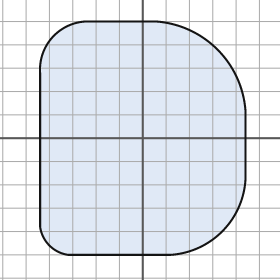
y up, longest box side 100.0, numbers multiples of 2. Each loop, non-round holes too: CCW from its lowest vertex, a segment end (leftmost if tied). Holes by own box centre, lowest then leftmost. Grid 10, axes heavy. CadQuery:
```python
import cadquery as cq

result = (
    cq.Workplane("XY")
    .moveTo(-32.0, -50.0)
    .lineTo(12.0, -50.0)
    .threePointArc((34.0, -40.0), (44.0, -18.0))
    .lineTo(44.0, 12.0)
    .threePointArc((32.0, 38.0), (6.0, 50.0))
    .lineTo(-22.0, 50.0)
    .threePointArc((-38.0, 44.0), (-44.0, 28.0))
    .lineTo(-44.0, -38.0)
    .threePointArc((-40.0, -46.0), (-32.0, -50.0))
    .close()
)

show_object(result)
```